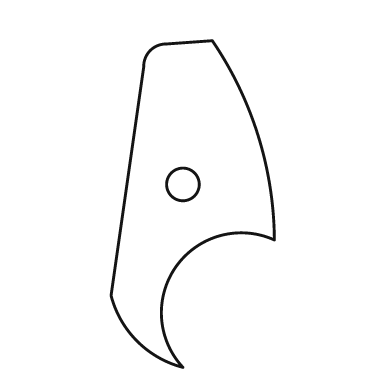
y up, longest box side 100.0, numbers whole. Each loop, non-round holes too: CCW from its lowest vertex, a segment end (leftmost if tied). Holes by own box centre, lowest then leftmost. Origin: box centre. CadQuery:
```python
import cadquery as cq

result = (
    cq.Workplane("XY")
    .moveTo(-3.0, -50.0)
    .threePointArc((-5.0, -19.0), (25.0, -11.0))
    .threePointArc((20.0, 21.0), (6.0, 50.0))
    .lineTo(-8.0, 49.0)
    .threePointArc((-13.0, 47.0), (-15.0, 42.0))
    .lineTo(-25.0, -28.0)
    .threePointArc((-17.0, -42.0), (-3.0, -50.0))
    .close()
    .moveTo(-3.0, 6.0)
    .circle(5.0)
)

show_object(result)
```